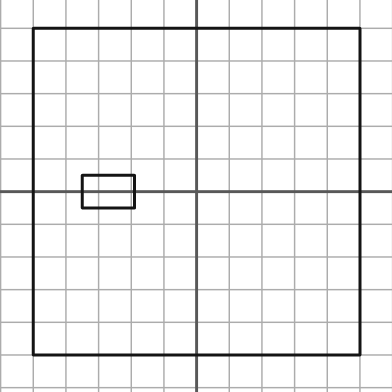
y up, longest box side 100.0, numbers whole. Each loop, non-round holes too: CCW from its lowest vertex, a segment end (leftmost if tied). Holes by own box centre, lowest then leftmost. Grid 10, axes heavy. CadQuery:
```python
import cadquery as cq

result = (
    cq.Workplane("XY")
    .moveTo(-50.0, -50.0)
    .lineTo(50.0, -50.0)
    .lineTo(50.0, 50.0)
    .lineTo(-50.0, 50.0)
    .close()
    .moveTo(-35.0, -5.0)
    .lineTo(-19.0, -5.0)
    .lineTo(-19.0, 5.0)
    .lineTo(-35.0, 5.0)
    .close()
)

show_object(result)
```